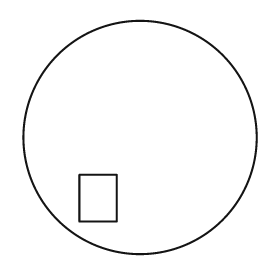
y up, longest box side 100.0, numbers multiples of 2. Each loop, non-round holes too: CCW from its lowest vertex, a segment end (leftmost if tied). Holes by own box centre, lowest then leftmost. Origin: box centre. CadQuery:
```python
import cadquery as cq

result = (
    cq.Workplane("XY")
    .moveTo(0.0, 0.0)
    .circle(50.0)
    .moveTo(-26.0, -36.0)
    .lineTo(-10.0, -36.0)
    .lineTo(-10.0, -16.0)
    .lineTo(-26.0, -16.0)
    .close()
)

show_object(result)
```